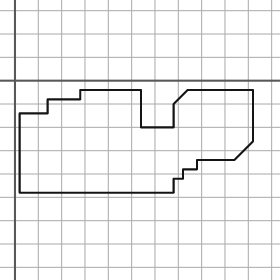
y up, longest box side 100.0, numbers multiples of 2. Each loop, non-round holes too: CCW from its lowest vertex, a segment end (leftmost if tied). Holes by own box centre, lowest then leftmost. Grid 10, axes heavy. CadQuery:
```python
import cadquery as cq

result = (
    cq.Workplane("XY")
    .moveTo(2.0, -48.0)
    .lineTo(68.0, -48.0)
    .lineTo(68.0, -42.0)
    .lineTo(72.0, -42.0)
    .lineTo(72.0, -38.0)
    .lineTo(78.0, -38.0)
    .lineTo(78.0, -34.0)
    .lineTo(94.0, -34.0)
    .lineTo(102.0, -26.0)
    .lineTo(102.0, -4.0)
    .lineTo(74.0, -4.0)
    .lineTo(68.0, -10.0)
    .lineTo(68.0, -20.0)
    .lineTo(54.0, -20.0)
    .lineTo(54.0, -4.0)
    .lineTo(28.0, -4.0)
    .lineTo(28.0, -8.0)
    .lineTo(14.0, -8.0)
    .lineTo(14.0, -14.0)
    .lineTo(2.0, -14.0)
    .close()
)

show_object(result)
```